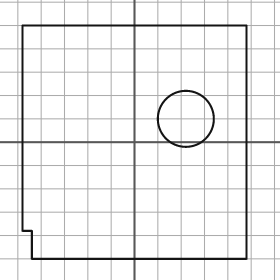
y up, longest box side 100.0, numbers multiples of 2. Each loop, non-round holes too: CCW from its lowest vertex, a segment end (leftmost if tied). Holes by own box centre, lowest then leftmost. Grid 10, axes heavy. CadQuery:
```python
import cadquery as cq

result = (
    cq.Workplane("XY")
    .moveTo(-44.0, -50.0)
    .lineTo(48.0, -50.0)
    .lineTo(48.0, 50.0)
    .lineTo(-48.0, 50.0)
    .lineTo(-48.0, -38.0)
    .lineTo(-44.0, -38.0)
    .close()
    .moveTo(22.0, 10.0)
    .circle(12.0)
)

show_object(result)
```